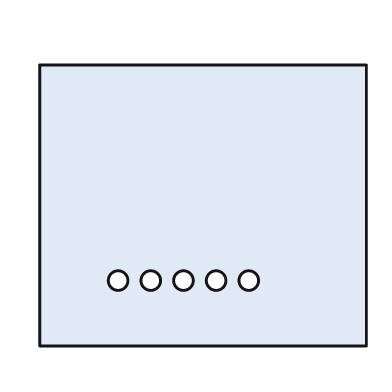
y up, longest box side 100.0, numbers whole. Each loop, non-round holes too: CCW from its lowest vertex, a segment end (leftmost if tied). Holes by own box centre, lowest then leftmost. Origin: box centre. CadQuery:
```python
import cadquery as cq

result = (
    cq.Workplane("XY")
    .moveTo(-50.0, -43.0)
    .lineTo(50.0, -43.0)
    .lineTo(50.0, 43.0)
    .lineTo(-50.0, 43.0)
    .close()
    .moveTo(-26.0, -23.0)
    .circle(3.0)
    .moveTo(-16.0, -23.0)
    .circle(3.0)
    .moveTo(-6.0, -23.0)
    .circle(3.0)
    .moveTo(4.0, -23.0)
    .circle(3.0)
    .moveTo(14.0, -23.0)
    .circle(3.0)
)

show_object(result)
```